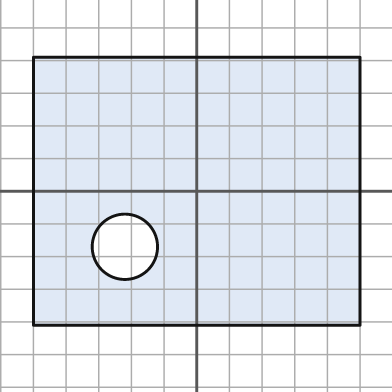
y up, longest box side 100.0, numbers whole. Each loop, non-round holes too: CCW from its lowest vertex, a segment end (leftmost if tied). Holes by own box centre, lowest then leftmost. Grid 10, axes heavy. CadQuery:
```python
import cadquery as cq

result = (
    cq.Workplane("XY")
    .moveTo(-50.0, -41.0)
    .lineTo(50.0, -41.0)
    .lineTo(50.0, 41.0)
    .lineTo(-50.0, 41.0)
    .close()
    .moveTo(-22.0, -17.0)
    .circle(10.0)
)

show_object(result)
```